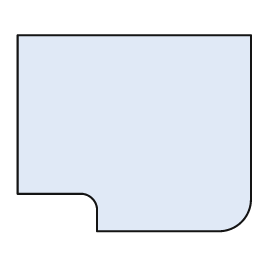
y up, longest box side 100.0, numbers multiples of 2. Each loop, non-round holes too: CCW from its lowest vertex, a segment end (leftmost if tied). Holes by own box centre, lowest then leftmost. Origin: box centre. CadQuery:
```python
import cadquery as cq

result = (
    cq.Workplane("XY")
    .moveTo(-16.0, -42.0)
    .lineTo(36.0, -42.0)
    .threePointArc((46.0, -38.0), (50.0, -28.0))
    .lineTo(50.0, 42.0)
    .lineTo(-50.0, 42.0)
    .lineTo(-50.0, -26.0)
    .lineTo(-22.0, -26.0)
    .threePointArc((-18.0, -28.0), (-16.0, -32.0))
    .close()
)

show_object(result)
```